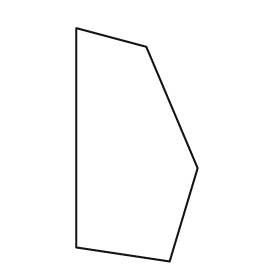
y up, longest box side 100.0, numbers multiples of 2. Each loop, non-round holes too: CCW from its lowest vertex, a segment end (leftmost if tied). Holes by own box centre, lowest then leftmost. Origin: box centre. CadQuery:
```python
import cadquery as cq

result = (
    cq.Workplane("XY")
    .moveTo(14.0, -50.0)
    .lineTo(26.0, -10.0)
    .lineTo(4.0, 42.0)
    .lineTo(-26.0, 50.0)
    .lineTo(-26.0, -44.0)
    .close()
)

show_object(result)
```